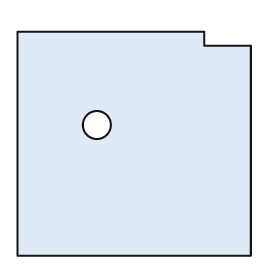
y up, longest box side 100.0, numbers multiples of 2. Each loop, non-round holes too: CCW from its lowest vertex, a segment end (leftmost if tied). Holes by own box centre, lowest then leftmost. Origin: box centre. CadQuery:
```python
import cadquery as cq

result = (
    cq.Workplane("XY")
    .moveTo(-50.0, -48.0)
    .lineTo(50.0, -48.0)
    .lineTo(50.0, 42.0)
    .lineTo(30.0, 42.0)
    .lineTo(30.0, 48.0)
    .lineTo(-50.0, 48.0)
    .close()
    .moveTo(-16.0, 8.0)
    .circle(6.0)
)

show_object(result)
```